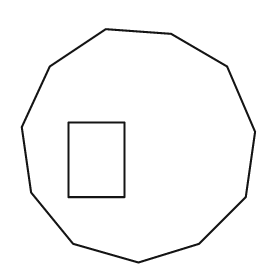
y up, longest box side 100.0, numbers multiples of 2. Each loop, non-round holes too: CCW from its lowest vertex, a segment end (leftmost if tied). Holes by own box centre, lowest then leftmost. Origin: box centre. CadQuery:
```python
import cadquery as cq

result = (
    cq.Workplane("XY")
    .moveTo(0.0, -50.0)
    .lineTo(26.0, -42.0)
    .lineTo(46.0, -22.0)
    .lineTo(50.0, 6.0)
    .lineTo(38.0, 34.0)
    .lineTo(14.0, 48.0)
    .lineTo(-14.0, 50.0)
    .lineTo(-38.0, 34.0)
    .lineTo(-50.0, 8.0)
    .lineTo(-46.0, -20.0)
    .lineTo(-28.0, -42.0)
    .close()
    .moveTo(-30.0, -22.0)
    .lineTo(-6.0, -22.0)
    .lineTo(-6.0, 10.0)
    .lineTo(-30.0, 10.0)
    .close()
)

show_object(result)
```